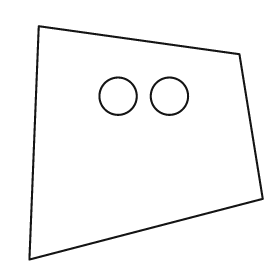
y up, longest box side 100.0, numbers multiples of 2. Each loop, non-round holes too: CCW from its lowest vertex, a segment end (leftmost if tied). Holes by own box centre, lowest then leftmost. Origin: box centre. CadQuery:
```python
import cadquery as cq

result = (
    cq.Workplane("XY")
    .moveTo(-50.0, -50.0)
    .lineTo(50.0, -24.0)
    .lineTo(40.0, 38.0)
    .lineTo(-46.0, 50.0)
    .close()
    .moveTo(-12.0, 20.0)
    .circle(8.0)
    .moveTo(10.0, 20.0)
    .circle(8.0)
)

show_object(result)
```